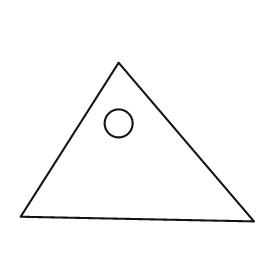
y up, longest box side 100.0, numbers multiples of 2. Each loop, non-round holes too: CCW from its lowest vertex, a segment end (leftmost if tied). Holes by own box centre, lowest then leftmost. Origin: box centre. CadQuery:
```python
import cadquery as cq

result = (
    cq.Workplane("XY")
    .moveTo(50.0, -34.0)
    .lineTo(-8.0, 34.0)
    .lineTo(-50.0, -32.0)
    .close()
    .moveTo(-8.0, 8.0)
    .circle(6.0)
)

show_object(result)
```